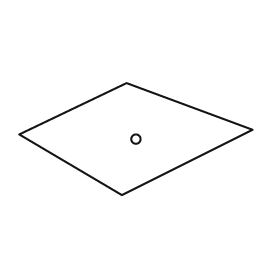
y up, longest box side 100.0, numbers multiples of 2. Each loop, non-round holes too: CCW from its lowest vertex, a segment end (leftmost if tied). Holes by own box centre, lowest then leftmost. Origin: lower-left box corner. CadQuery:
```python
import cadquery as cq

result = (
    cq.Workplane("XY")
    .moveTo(44.0, 0.0)
    .lineTo(100.0, 28.0)
    .lineTo(46.0, 48.0)
    .lineTo(0.0, 26.0)
    .close()
    .moveTo(50.0, 24.0)
    .circle(2.0)
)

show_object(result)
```